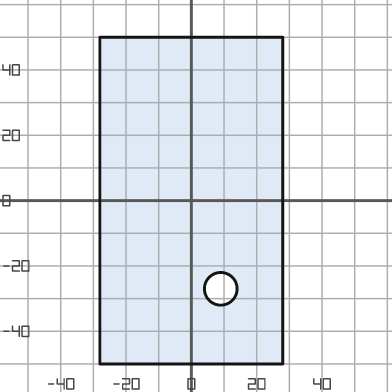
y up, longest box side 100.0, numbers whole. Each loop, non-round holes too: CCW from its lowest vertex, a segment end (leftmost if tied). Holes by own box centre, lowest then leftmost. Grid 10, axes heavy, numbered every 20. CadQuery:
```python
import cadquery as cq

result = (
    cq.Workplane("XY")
    .moveTo(-28.0, -50.0)
    .lineTo(28.0, -50.0)
    .lineTo(28.0, 50.0)
    .lineTo(-28.0, 50.0)
    .close()
    .moveTo(9.0, -27.0)
    .circle(5.0)
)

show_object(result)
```